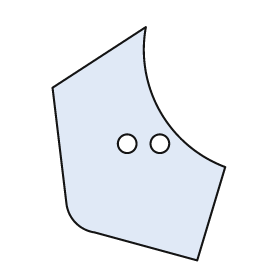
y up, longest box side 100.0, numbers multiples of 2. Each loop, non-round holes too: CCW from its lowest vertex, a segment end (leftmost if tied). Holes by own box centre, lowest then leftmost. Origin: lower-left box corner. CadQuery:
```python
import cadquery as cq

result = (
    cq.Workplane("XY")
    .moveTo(62.0, 0.0)
    .lineTo(74.0, 40.0)
    .threePointArc((46.0, 64.0), (40.0, 100.0))
    .lineTo(0.0, 74.0)
    .lineTo(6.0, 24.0)
    .threePointArc((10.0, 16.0), (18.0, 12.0))
    .close()
    .moveTo(32.0, 50.0)
    .circle(4.0)
    .moveTo(46.0, 50.0)
    .circle(4.0)
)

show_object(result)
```